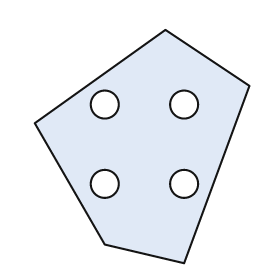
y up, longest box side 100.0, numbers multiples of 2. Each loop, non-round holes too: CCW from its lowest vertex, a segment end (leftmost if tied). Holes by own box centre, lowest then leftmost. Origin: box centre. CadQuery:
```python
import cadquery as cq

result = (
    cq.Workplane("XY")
    .moveTo(18.0, -50.0)
    .lineTo(46.0, 26.0)
    .lineTo(10.0, 50.0)
    .lineTo(-46.0, 10.0)
    .lineTo(-16.0, -42.0)
    .close()
    .moveTo(-16.0, -16.0)
    .circle(6.0)
    .moveTo(18.0, -16.0)
    .circle(6.0)
    .moveTo(-16.0, 18.0)
    .circle(6.0)
    .moveTo(18.0, 18.0)
    .circle(6.0)
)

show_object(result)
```